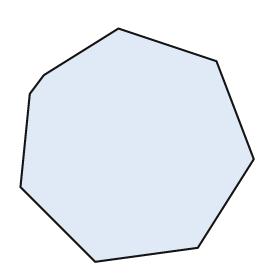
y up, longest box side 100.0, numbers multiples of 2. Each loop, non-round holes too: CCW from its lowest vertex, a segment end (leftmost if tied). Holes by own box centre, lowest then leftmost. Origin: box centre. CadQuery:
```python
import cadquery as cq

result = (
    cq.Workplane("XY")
    .moveTo(-18.0, -50.0)
    .lineTo(26.0, -44.0)
    .lineTo(50.0, -6.0)
    .lineTo(34.0, 36.0)
    .lineTo(-8.0, 50.0)
    .lineTo(-40.0, 30.0)
    .lineTo(-46.0, 22.0)
    .lineTo(-50.0, -18.0)
    .close()
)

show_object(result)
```